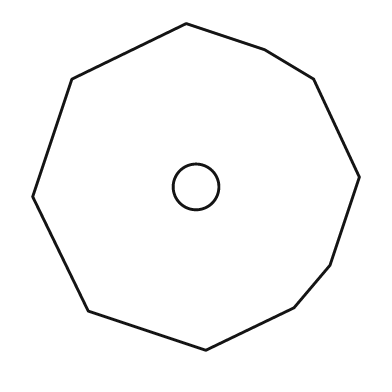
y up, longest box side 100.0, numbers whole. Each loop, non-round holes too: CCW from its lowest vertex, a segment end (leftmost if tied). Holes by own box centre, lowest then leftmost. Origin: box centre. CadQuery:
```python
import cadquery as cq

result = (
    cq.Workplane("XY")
    .moveTo(3.0, -50.0)
    .lineTo(30.0, -37.0)
    .lineTo(41.0, -24.0)
    .lineTo(50.0, 3.0)
    .lineTo(36.0, 33.0)
    .lineTo(21.0, 42.0)
    .lineTo(-3.0, 50.0)
    .lineTo(-38.0, 33.0)
    .lineTo(-50.0, -3.0)
    .lineTo(-33.0, -38.0)
    .close()
    .moveTo(0.0, 0.0)
    .circle(7.0)
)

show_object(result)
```